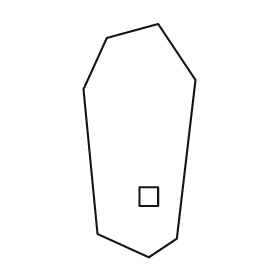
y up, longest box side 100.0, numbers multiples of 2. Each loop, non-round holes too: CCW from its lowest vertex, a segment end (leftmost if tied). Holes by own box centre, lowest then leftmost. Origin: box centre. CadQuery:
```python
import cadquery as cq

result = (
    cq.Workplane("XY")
    .moveTo(4.0, -50.0)
    .lineTo(16.0, -42.0)
    .lineTo(24.0, 26.0)
    .lineTo(8.0, 50.0)
    .lineTo(-14.0, 44.0)
    .lineTo(-24.0, 22.0)
    .lineTo(-18.0, -40.0)
    .close()
    .moveTo(0.0, -28.0)
    .lineTo(8.0, -28.0)
    .lineTo(8.0, -20.0)
    .lineTo(0.0, -20.0)
    .close()
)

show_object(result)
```